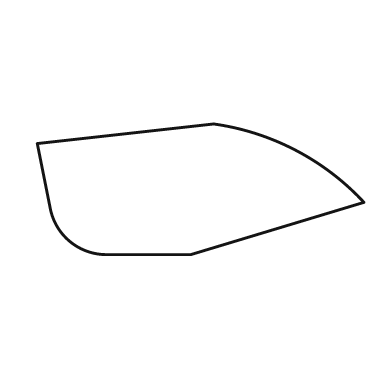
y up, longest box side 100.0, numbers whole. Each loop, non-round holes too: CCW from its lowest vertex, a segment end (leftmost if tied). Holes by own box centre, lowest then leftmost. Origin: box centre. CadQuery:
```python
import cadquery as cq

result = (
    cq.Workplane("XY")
    .moveTo(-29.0, -20.0)
    .lineTo(-3.0, -20.0)
    .lineTo(50.0, -4.0)
    .threePointArc((29.0, 12.0), (4.0, 20.0))
    .lineTo(-50.0, 14.0)
    .lineTo(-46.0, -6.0)
    .threePointArc((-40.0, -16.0), (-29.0, -20.0))
    .close()
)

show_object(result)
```